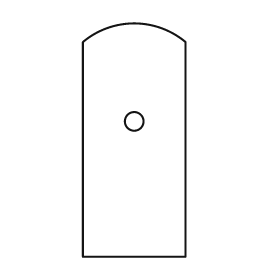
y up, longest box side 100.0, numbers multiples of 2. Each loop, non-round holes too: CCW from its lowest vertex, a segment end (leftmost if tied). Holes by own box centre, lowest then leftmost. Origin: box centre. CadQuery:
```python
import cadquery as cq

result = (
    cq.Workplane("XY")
    .moveTo(-22.0, -50.0)
    .lineTo(22.0, -50.0)
    .lineTo(22.0, 42.0)
    .threePointArc((0.0, 50.0), (-22.0, 42.0))
    .close()
    .moveTo(0.0, 8.0)
    .circle(4.0)
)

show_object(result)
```